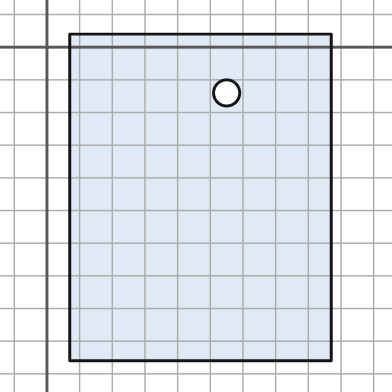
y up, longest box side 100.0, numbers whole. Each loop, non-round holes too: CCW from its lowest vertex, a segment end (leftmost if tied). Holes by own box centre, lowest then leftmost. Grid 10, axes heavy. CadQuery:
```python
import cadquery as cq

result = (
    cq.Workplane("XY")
    .moveTo(7.0, -96.0)
    .lineTo(87.0, -96.0)
    .lineTo(87.0, 4.0)
    .lineTo(7.0, 4.0)
    .close()
    .moveTo(55.0, -14.0)
    .circle(4.0)
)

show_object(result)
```